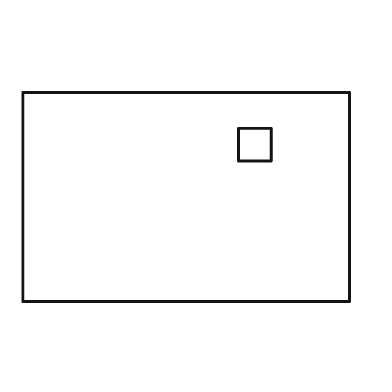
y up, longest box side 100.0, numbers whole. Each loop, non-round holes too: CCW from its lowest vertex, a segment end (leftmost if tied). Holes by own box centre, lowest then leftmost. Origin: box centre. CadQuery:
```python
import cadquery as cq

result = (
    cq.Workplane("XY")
    .moveTo(-50.0, -32.0)
    .lineTo(50.0, -32.0)
    .lineTo(50.0, 32.0)
    .lineTo(-50.0, 32.0)
    .close()
    .moveTo(16.0, 11.0)
    .lineTo(26.0, 11.0)
    .lineTo(26.0, 21.0)
    .lineTo(16.0, 21.0)
    .close()
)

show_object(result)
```